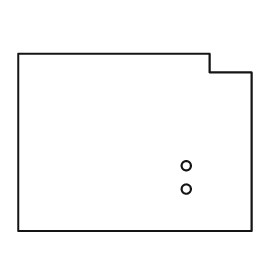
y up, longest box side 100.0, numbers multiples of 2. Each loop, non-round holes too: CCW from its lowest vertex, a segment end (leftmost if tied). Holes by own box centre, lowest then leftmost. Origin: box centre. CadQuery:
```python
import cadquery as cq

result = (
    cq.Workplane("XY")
    .moveTo(-50.0, -38.0)
    .lineTo(50.0, -38.0)
    .lineTo(50.0, 30.0)
    .lineTo(32.0, 30.0)
    .lineTo(32.0, 38.0)
    .lineTo(-50.0, 38.0)
    .close()
    .moveTo(22.0, -20.0)
    .circle(2.0)
    .moveTo(22.0, -10.0)
    .circle(2.0)
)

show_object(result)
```